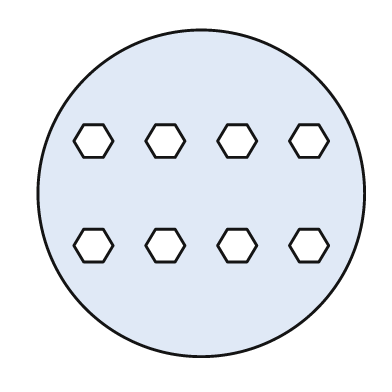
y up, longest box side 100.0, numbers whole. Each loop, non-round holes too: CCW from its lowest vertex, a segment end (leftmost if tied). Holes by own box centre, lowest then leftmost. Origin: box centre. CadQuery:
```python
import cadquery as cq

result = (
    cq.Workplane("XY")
    .moveTo(0.0, 0.0)
    .circle(50.0)
    .moveTo(-36.0, -21.0)
    .lineTo(-30.0, -21.0)
    .lineTo(-27.0, -16.0)
    .lineTo(-30.0, -11.0)
    .lineTo(-36.0, -11.0)
    .lineTo(-39.0, -16.0)
    .close()
    .moveTo(-14.0, -21.0)
    .lineTo(-8.0, -21.0)
    .lineTo(-5.0, -16.0)
    .lineTo(-8.0, -11.0)
    .lineTo(-14.0, -11.0)
    .lineTo(-17.0, -16.0)
    .close()
    .moveTo(8.0, -21.0)
    .lineTo(14.0, -21.0)
    .lineTo(17.0, -16.0)
    .lineTo(14.0, -11.0)
    .lineTo(8.0, -11.0)
    .lineTo(5.0, -16.0)
    .close()
    .moveTo(30.0, -21.0)
    .lineTo(36.0, -21.0)
    .lineTo(39.0, -16.0)
    .lineTo(36.0, -11.0)
    .lineTo(30.0, -11.0)
    .lineTo(27.0, -16.0)
    .close()
    .moveTo(-36.0, 11.0)
    .lineTo(-30.0, 11.0)
    .lineTo(-27.0, 16.0)
    .lineTo(-30.0, 21.0)
    .lineTo(-36.0, 21.0)
    .lineTo(-39.0, 16.0)
    .close()
    .moveTo(-14.0, 11.0)
    .lineTo(-8.0, 11.0)
    .lineTo(-5.0, 16.0)
    .lineTo(-8.0, 21.0)
    .lineTo(-14.0, 21.0)
    .lineTo(-17.0, 16.0)
    .close()
    .moveTo(8.0, 11.0)
    .lineTo(14.0, 11.0)
    .lineTo(17.0, 16.0)
    .lineTo(14.0, 21.0)
    .lineTo(8.0, 21.0)
    .lineTo(5.0, 16.0)
    .close()
    .moveTo(30.0, 11.0)
    .lineTo(36.0, 11.0)
    .lineTo(39.0, 16.0)
    .lineTo(36.0, 21.0)
    .lineTo(30.0, 21.0)
    .lineTo(27.0, 16.0)
    .close()
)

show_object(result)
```